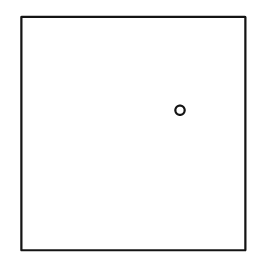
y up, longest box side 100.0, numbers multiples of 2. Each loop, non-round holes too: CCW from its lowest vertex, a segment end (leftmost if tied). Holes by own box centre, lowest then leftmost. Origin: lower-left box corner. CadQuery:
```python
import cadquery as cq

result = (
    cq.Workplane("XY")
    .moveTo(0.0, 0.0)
    .lineTo(96.0, 0.0)
    .lineTo(96.0, 100.0)
    .lineTo(0.0, 100.0)
    .close()
    .moveTo(68.0, 60.0)
    .circle(2.0)
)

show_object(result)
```